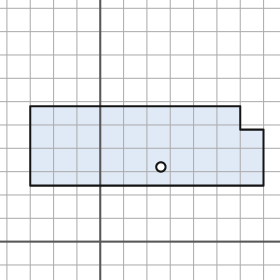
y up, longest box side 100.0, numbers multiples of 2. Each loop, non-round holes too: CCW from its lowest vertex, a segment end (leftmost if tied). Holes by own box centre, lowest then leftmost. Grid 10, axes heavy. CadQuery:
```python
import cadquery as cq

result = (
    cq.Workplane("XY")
    .moveTo(-30.0, 24.0)
    .lineTo(70.0, 24.0)
    .lineTo(70.0, 48.0)
    .lineTo(60.0, 48.0)
    .lineTo(60.0, 58.0)
    .lineTo(-30.0, 58.0)
    .close()
    .moveTo(26.0, 32.0)
    .circle(2.0)
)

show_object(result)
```